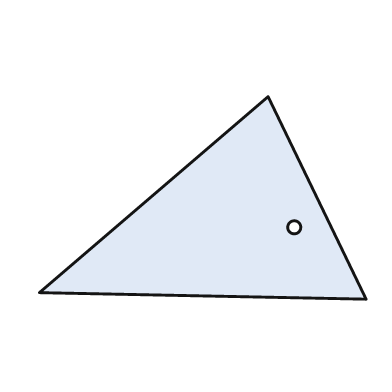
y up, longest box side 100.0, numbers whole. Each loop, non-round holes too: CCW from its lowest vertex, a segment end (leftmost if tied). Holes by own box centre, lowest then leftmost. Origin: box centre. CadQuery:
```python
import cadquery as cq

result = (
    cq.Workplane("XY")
    .moveTo(50.0, -31.0)
    .lineTo(20.0, 31.0)
    .lineTo(-50.0, -29.0)
    .close()
    .moveTo(28.0, -9.0)
    .circle(2.0)
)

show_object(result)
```